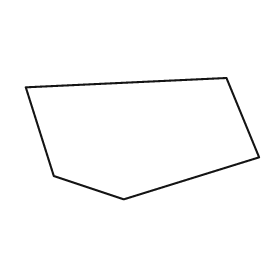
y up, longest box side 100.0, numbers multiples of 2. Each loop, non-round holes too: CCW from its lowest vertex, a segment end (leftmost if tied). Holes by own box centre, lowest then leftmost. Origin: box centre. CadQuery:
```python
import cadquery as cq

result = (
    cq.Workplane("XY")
    .moveTo(-8.0, -26.0)
    .lineTo(50.0, -8.0)
    .lineTo(36.0, 26.0)
    .lineTo(-50.0, 22.0)
    .lineTo(-38.0, -16.0)
    .close()
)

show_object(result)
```